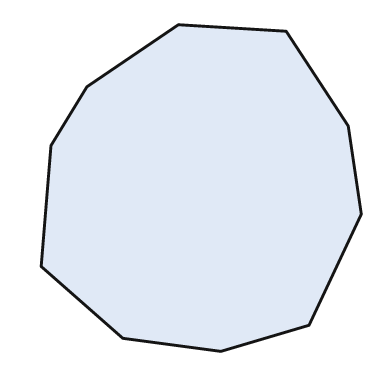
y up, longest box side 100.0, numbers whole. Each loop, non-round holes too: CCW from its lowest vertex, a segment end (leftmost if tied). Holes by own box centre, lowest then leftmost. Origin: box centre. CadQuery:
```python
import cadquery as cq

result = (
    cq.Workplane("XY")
    .moveTo(6.0, -50.0)
    .lineTo(33.0, -42.0)
    .lineTo(49.0, -8.0)
    .lineTo(45.0, 19.0)
    .lineTo(26.0, 48.0)
    .lineTo(-7.0, 50.0)
    .lineTo(-35.0, 31.0)
    .lineTo(-46.0, 13.0)
    .lineTo(-49.0, -24.0)
    .lineTo(-24.0, -46.0)
    .close()
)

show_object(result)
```